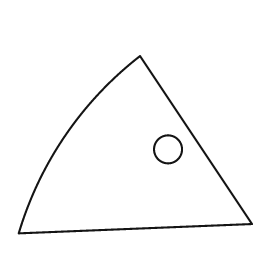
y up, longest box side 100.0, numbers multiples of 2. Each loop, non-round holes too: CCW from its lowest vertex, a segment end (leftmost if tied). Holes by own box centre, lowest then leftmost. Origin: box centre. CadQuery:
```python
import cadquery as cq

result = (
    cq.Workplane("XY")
    .moveTo(-50.0, -38.0)
    .lineTo(50.0, -34.0)
    .lineTo(2.0, 38.0)
    .threePointArc((-30.0, 4.0), (-50.0, -38.0))
    .close()
    .moveTo(14.0, -2.0)
    .circle(6.0)
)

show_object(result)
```